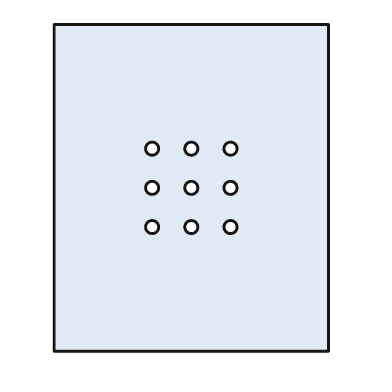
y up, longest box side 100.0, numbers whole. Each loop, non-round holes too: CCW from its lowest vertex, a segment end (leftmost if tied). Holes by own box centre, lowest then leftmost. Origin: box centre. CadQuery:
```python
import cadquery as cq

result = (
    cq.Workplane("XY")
    .moveTo(-42.0, -50.0)
    .lineTo(42.0, -50.0)
    .lineTo(42.0, 50.0)
    .lineTo(-42.0, 50.0)
    .close()
    .moveTo(-12.0, -12.0)
    .circle(2.0)
    .moveTo(0.0, -12.0)
    .circle(2.0)
    .moveTo(12.0, -12.0)
    .circle(2.0)
    .moveTo(-12.0, 0.0)
    .circle(2.0)
    .moveTo(0.0, 0.0)
    .circle(2.0)
    .moveTo(12.0, 0.0)
    .circle(2.0)
    .moveTo(-12.0, 12.0)
    .circle(2.0)
    .moveTo(0.0, 12.0)
    .circle(2.0)
    .moveTo(12.0, 12.0)
    .circle(2.0)
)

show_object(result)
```